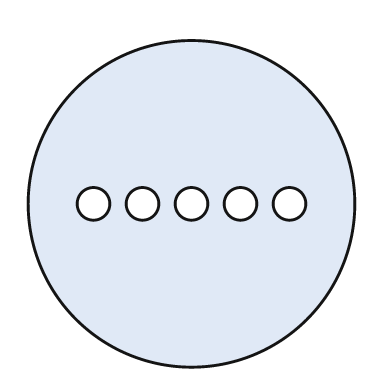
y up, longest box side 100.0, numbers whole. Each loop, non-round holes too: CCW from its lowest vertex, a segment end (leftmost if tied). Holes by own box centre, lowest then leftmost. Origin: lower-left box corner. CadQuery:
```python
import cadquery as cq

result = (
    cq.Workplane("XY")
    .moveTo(50.0, 50.0)
    .circle(50.0)
    .moveTo(20.0, 50.0)
    .circle(5.0)
    .moveTo(35.0, 50.0)
    .circle(5.0)
    .moveTo(50.0, 50.0)
    .circle(5.0)
    .moveTo(65.0, 50.0)
    .circle(5.0)
    .moveTo(80.0, 50.0)
    .circle(5.0)
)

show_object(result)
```